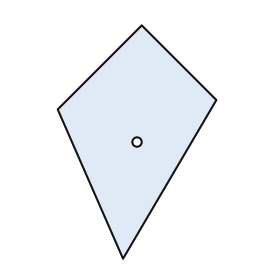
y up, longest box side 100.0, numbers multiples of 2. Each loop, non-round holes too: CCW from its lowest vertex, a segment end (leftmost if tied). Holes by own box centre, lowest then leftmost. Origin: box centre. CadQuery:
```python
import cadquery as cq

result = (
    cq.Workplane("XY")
    .moveTo(-6.0, -50.0)
    .lineTo(34.0, 18.0)
    .lineTo(2.0, 50.0)
    .lineTo(-34.0, 14.0)
    .close()
    .moveTo(0.0, 0.0)
    .circle(2.0)
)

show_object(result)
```